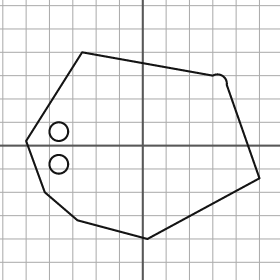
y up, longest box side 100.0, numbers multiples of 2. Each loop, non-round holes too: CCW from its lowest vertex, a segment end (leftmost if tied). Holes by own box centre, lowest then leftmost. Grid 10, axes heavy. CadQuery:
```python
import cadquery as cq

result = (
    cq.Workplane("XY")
    .moveTo(2.0, -40.0)
    .lineTo(50.0, -14.0)
    .lineTo(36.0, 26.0)
    .threePointArc((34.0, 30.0), (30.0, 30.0))
    .lineTo(-26.0, 40.0)
    .lineTo(-50.0, 2.0)
    .lineTo(-42.0, -20.0)
    .lineTo(-28.0, -32.0)
    .close()
    .moveTo(-36.0, -8.0)
    .circle(4.0)
    .moveTo(-36.0, 6.0)
    .circle(4.0)
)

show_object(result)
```